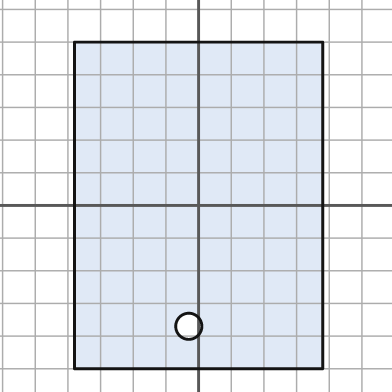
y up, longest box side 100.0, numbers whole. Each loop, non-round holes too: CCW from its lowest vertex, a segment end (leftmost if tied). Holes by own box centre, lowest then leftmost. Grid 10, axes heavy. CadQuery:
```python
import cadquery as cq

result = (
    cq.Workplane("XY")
    .moveTo(-38.0, -50.0)
    .lineTo(38.0, -50.0)
    .lineTo(38.0, 50.0)
    .lineTo(-38.0, 50.0)
    .close()
    .moveTo(-3.0, -37.0)
    .circle(4.0)
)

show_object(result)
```